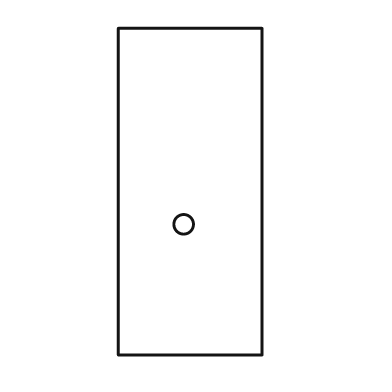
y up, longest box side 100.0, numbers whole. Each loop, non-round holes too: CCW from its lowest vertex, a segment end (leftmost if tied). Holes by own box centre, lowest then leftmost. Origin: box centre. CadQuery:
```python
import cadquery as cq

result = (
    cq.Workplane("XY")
    .moveTo(-22.0, -50.0)
    .lineTo(22.0, -50.0)
    .lineTo(22.0, 50.0)
    .lineTo(-22.0, 50.0)
    .close()
    .moveTo(-2.0, -10.0)
    .circle(3.0)
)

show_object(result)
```